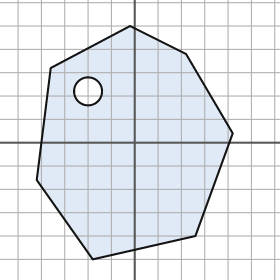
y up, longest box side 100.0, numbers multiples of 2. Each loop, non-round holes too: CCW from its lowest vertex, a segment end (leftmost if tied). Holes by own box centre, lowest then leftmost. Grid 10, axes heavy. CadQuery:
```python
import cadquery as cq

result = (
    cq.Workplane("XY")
    .moveTo(-18.0, -50.0)
    .lineTo(26.0, -40.0)
    .lineTo(42.0, 4.0)
    .lineTo(22.0, 38.0)
    .lineTo(-2.0, 50.0)
    .lineTo(-36.0, 32.0)
    .lineTo(-42.0, -16.0)
    .close()
    .moveTo(-20.0, 22.0)
    .circle(6.0)
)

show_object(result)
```